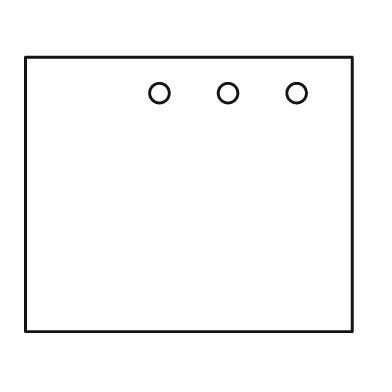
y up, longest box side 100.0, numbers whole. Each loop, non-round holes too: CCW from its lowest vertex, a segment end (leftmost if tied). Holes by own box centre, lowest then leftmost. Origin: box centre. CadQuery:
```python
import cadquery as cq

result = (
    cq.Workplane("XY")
    .moveTo(-50.0, -42.0)
    .lineTo(50.0, -42.0)
    .lineTo(50.0, 42.0)
    .lineTo(-50.0, 42.0)
    .close()
    .moveTo(-9.0, 31.0)
    .circle(3.0)
    .moveTo(12.0, 31.0)
    .circle(3.0)
    .moveTo(33.0, 31.0)
    .circle(3.0)
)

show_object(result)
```